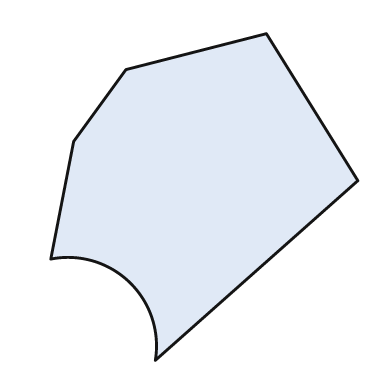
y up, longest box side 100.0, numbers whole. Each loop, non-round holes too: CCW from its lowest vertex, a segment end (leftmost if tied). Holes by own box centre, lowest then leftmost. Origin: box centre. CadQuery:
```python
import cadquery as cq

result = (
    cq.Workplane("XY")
    .moveTo(-15.0, -50.0)
    .lineTo(47.0, 5.0)
    .lineTo(19.0, 50.0)
    .lineTo(-24.0, 39.0)
    .lineTo(-40.0, 17.0)
    .lineTo(-47.0, -19.0)
    .threePointArc((-23.0, -26.0), (-15.0, -50.0))
    .close()
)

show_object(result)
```